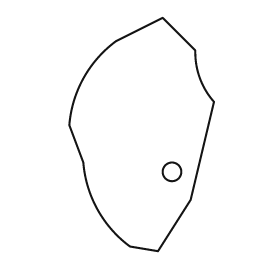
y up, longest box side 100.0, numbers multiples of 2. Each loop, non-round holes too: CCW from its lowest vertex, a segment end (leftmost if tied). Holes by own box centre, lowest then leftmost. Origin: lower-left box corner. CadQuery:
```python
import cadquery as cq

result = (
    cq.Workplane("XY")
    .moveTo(38.0, 0.0)
    .lineTo(52.0, 22.0)
    .lineTo(62.0, 64.0)
    .threePointArc((56.0, 74.0), (54.0, 86.0))
    .lineTo(40.0, 100.0)
    .lineTo(20.0, 90.0)
    .threePointArc((6.0, 74.0), (0.0, 54.0))
    .lineTo(6.0, 38.0)
    .threePointArc((12.0, 18.0), (26.0, 2.0))
    .close()
    .moveTo(44.0, 34.0)
    .circle(4.0)
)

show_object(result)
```